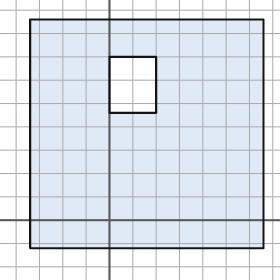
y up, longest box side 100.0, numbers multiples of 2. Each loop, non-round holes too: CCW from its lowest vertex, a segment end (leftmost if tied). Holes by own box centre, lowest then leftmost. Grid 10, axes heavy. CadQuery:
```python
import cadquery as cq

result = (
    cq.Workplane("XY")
    .moveTo(-34.0, -12.0)
    .lineTo(66.0, -12.0)
    .lineTo(66.0, 86.0)
    .lineTo(-34.0, 86.0)
    .close()
    .moveTo(0.0, 46.0)
    .lineTo(20.0, 46.0)
    .lineTo(20.0, 70.0)
    .lineTo(0.0, 70.0)
    .close()
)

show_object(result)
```